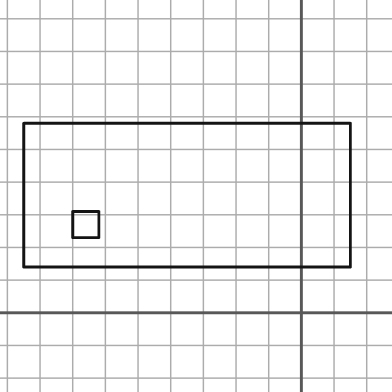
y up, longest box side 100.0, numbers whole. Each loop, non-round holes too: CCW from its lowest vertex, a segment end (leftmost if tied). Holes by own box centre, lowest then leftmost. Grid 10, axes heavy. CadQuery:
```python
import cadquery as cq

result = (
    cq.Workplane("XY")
    .moveTo(-85.0, 14.0)
    .lineTo(15.0, 14.0)
    .lineTo(15.0, 58.0)
    .lineTo(-85.0, 58.0)
    .close()
    .moveTo(-70.0, 23.0)
    .lineTo(-62.0, 23.0)
    .lineTo(-62.0, 31.0)
    .lineTo(-70.0, 31.0)
    .close()
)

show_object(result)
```